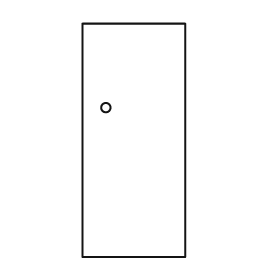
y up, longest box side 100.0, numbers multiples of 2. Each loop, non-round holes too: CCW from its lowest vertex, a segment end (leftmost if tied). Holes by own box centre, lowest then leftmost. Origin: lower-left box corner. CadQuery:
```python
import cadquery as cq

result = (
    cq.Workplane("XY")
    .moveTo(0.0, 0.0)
    .lineTo(44.0, 0.0)
    .lineTo(44.0, 100.0)
    .lineTo(0.0, 100.0)
    .close()
    .moveTo(10.0, 64.0)
    .circle(2.0)
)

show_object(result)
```